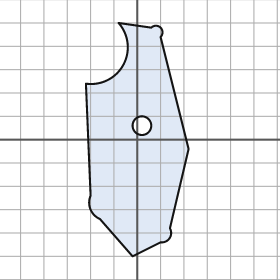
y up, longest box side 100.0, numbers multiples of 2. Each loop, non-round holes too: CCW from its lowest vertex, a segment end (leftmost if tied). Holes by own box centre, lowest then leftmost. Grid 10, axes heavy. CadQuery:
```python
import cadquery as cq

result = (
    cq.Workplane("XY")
    .moveTo(-2.0, -50.0)
    .lineTo(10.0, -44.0)
    .threePointArc((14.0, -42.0), (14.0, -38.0))
    .lineTo(22.0, -4.0)
    .lineTo(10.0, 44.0)
    .threePointArc((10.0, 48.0), (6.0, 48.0))
    .lineTo(-8.0, 50.0)
    .threePointArc((-6.0, 32.0), (-22.0, 24.0))
    .lineTo(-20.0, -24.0)
    .threePointArc((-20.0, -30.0), (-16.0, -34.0))
    .close()
    .moveTo(2.0, 6.0)
    .circle(4.0)
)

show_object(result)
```